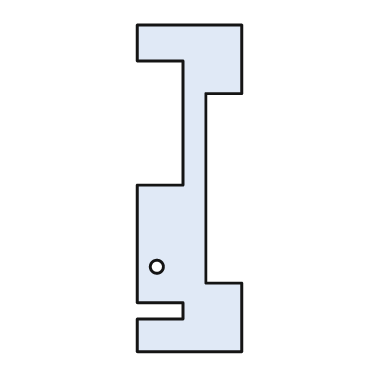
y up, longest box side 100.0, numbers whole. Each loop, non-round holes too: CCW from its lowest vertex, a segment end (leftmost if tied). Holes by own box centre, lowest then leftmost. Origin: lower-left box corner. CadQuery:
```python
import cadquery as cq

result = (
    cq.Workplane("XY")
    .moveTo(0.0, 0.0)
    .lineTo(32.0, 0.0)
    .lineTo(32.0, 21.0)
    .lineTo(21.0, 21.0)
    .lineTo(21.0, 79.0)
    .lineTo(32.0, 79.0)
    .lineTo(32.0, 100.0)
    .lineTo(0.0, 100.0)
    .lineTo(0.0, 89.0)
    .lineTo(14.0, 89.0)
    .lineTo(14.0, 51.0)
    .lineTo(0.0, 51.0)
    .lineTo(0.0, 15.0)
    .lineTo(14.0, 15.0)
    .lineTo(14.0, 10.0)
    .lineTo(0.0, 10.0)
    .close()
    .moveTo(6.0, 26.0)
    .circle(2.0)
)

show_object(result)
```